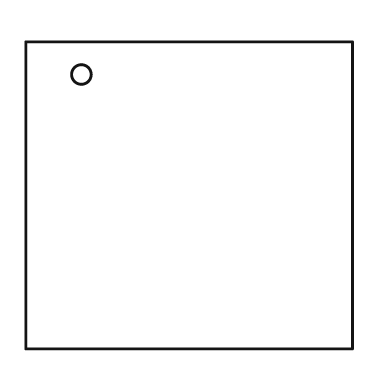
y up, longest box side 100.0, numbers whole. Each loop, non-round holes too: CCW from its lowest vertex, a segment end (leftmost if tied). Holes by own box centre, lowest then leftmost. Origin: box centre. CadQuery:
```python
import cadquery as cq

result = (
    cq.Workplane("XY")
    .moveTo(-50.0, -47.0)
    .lineTo(50.0, -47.0)
    .lineTo(50.0, 47.0)
    .lineTo(-50.0, 47.0)
    .close()
    .moveTo(-33.0, 37.0)
    .circle(3.0)
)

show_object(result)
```